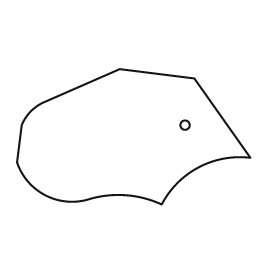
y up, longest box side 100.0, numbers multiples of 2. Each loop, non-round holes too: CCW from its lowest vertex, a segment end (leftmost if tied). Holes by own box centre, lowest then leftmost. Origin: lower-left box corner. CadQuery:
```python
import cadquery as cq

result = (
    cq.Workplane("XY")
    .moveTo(62.0, 0.0)
    .threePointArc((78.0, 16.0), (100.0, 20.0))
    .lineTo(76.0, 54.0)
    .lineTo(44.0, 58.0)
    .lineTo(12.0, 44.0)
    .threePointArc((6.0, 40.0), (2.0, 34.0))
    .lineTo(0.0, 18.0)
    .threePointArc((12.0, 4.0), (30.0, 2.0))
    .threePointArc((46.0, 4.0), (62.0, 0.0))
    .close()
    .moveTo(72.0, 34.0)
    .circle(2.0)
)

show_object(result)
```